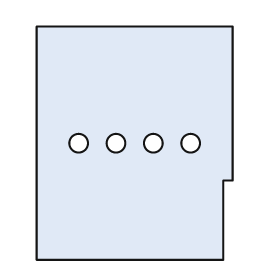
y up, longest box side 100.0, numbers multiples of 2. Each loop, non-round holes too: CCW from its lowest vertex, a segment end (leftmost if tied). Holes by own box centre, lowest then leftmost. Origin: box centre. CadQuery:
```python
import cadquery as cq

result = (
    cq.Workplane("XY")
    .moveTo(-42.0, -50.0)
    .lineTo(38.0, -50.0)
    .lineTo(38.0, -16.0)
    .lineTo(42.0, -16.0)
    .lineTo(42.0, 50.0)
    .lineTo(-42.0, 50.0)
    .close()
    .moveTo(-24.0, 0.0)
    .circle(4.0)
    .moveTo(-8.0, 0.0)
    .circle(4.0)
    .moveTo(8.0, 0.0)
    .circle(4.0)
    .moveTo(24.0, 0.0)
    .circle(4.0)
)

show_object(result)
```